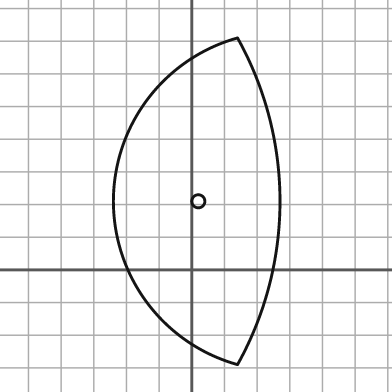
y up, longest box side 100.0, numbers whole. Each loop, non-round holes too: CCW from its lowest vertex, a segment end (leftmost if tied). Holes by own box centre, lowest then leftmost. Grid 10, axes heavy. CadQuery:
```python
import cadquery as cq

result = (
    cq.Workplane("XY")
    .moveTo(14.0, -29.0)
    .threePointArc((27.0, 21.0), (14.0, 71.0))
    .threePointArc((-24.0, 21.0), (14.0, -29.0))
    .close()
    .moveTo(2.0, 21.0)
    .circle(2.0)
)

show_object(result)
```